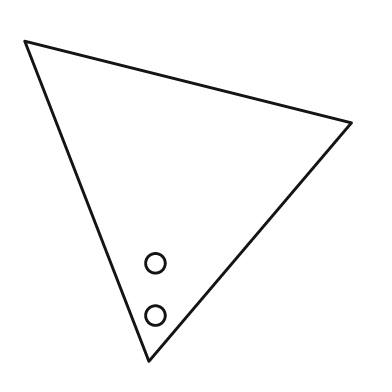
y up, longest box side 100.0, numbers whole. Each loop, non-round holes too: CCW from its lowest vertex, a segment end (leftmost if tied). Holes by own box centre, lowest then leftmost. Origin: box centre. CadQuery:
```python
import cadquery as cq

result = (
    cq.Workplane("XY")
    .moveTo(-12.0, -49.0)
    .lineTo(50.0, 24.0)
    .lineTo(-50.0, 49.0)
    .close()
    .moveTo(-10.0, -35.0)
    .circle(3.0)
    .moveTo(-10.0, -19.0)
    .circle(3.0)
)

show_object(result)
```